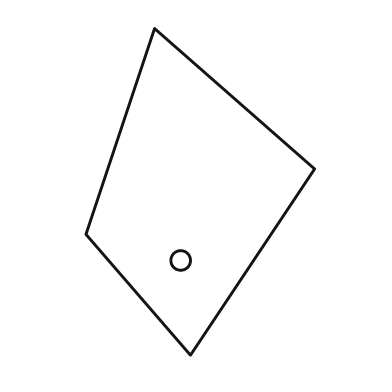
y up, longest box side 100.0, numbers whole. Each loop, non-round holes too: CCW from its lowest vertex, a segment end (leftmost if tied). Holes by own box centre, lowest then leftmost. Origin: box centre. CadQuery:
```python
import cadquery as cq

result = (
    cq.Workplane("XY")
    .moveTo(-3.0, -50.0)
    .lineTo(35.0, 7.0)
    .lineTo(-14.0, 50.0)
    .lineTo(-35.0, -13.0)
    .close()
    .moveTo(-6.0, -21.0)
    .circle(3.0)
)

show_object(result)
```